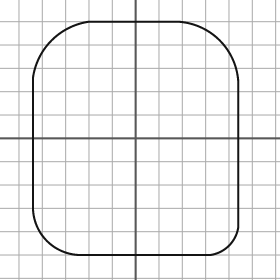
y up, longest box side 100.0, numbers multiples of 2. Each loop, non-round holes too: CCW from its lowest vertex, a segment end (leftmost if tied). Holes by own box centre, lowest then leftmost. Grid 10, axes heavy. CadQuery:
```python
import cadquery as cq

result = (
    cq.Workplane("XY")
    .moveTo(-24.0, -50.0)
    .lineTo(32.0, -50.0)
    .threePointArc((40.0, -46.0), (44.0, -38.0))
    .lineTo(44.0, 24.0)
    .threePointArc((36.0, 42.0), (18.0, 50.0))
    .lineTo(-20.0, 50.0)
    .threePointArc((-36.0, 42.0), (-44.0, 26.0))
    .lineTo(-44.0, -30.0)
    .threePointArc((-38.0, -44.0), (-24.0, -50.0))
    .close()
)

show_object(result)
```